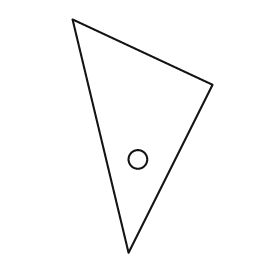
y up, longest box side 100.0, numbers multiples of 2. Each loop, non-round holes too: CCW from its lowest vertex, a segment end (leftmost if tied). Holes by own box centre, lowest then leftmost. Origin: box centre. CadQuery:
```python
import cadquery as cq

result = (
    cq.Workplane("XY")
    .moveTo(-6.0, -50.0)
    .lineTo(30.0, 22.0)
    .lineTo(-30.0, 50.0)
    .close()
    .moveTo(-2.0, -10.0)
    .circle(4.0)
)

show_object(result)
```